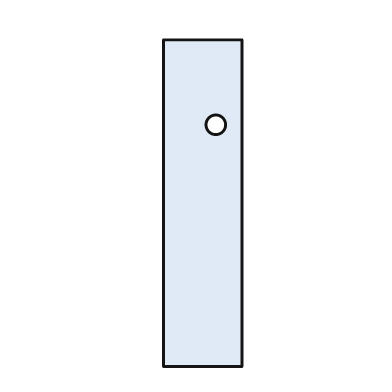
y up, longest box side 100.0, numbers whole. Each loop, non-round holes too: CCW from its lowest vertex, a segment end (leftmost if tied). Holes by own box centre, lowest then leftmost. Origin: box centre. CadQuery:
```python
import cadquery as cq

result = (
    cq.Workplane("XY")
    .moveTo(-12.0, -50.0)
    .lineTo(12.0, -50.0)
    .lineTo(12.0, 50.0)
    .lineTo(-12.0, 50.0)
    .close()
    .moveTo(4.0, 24.0)
    .circle(3.0)
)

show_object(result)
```